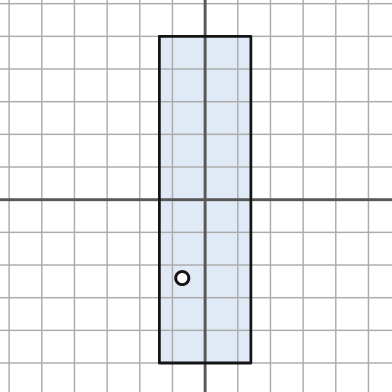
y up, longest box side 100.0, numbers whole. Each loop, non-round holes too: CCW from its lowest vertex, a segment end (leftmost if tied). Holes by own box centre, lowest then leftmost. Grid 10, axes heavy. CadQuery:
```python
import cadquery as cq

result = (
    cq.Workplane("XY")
    .moveTo(-14.0, -50.0)
    .lineTo(14.0, -50.0)
    .lineTo(14.0, 50.0)
    .lineTo(-14.0, 50.0)
    .close()
    .moveTo(-7.0, -24.0)
    .circle(2.0)
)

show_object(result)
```